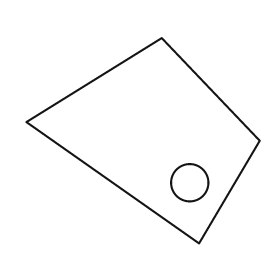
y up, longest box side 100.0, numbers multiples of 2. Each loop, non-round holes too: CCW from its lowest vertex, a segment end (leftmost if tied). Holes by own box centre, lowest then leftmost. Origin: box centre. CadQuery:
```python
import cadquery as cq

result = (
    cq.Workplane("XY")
    .moveTo(24.0, -44.0)
    .lineTo(50.0, 0.0)
    .lineTo(8.0, 44.0)
    .lineTo(-50.0, 8.0)
    .close()
    .moveTo(20.0, -18.0)
    .circle(8.0)
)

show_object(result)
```